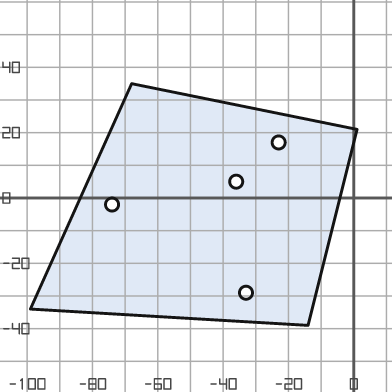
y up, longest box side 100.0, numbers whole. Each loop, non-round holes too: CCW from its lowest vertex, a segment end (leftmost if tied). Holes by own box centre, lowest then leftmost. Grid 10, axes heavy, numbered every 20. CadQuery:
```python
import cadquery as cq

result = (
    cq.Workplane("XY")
    .moveTo(-14.0, -39.0)
    .lineTo(1.0, 21.0)
    .lineTo(-68.0, 35.0)
    .lineTo(-99.0, -34.0)
    .close()
    .moveTo(-33.0, -29.0)
    .circle(2.0)
    .moveTo(-74.0, -2.0)
    .circle(2.0)
    .moveTo(-36.0, 5.0)
    .circle(2.0)
    .moveTo(-23.0, 17.0)
    .circle(2.0)
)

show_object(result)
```